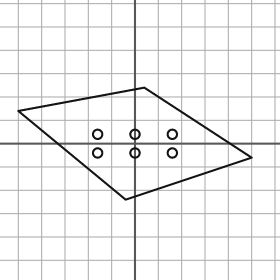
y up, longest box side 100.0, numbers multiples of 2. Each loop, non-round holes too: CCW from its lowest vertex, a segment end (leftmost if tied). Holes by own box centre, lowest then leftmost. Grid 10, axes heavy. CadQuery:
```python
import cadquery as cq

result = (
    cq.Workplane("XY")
    .moveTo(-4.0, -24.0)
    .lineTo(50.0, -6.0)
    .lineTo(4.0, 24.0)
    .lineTo(-50.0, 14.0)
    .close()
    .moveTo(-16.0, -4.0)
    .circle(2.0)
    .moveTo(0.0, -4.0)
    .circle(2.0)
    .moveTo(16.0, -4.0)
    .circle(2.0)
    .moveTo(-16.0, 4.0)
    .circle(2.0)
    .moveTo(0.0, 4.0)
    .circle(2.0)
    .moveTo(16.0, 4.0)
    .circle(2.0)
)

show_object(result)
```